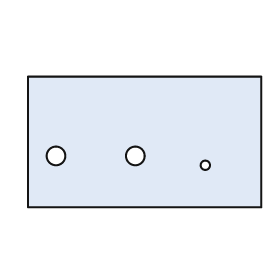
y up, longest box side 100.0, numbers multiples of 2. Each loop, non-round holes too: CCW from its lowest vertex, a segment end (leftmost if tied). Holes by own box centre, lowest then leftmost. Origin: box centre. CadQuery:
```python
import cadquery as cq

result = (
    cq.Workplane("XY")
    .moveTo(-50.0, -28.0)
    .lineTo(50.0, -28.0)
    .lineTo(50.0, 28.0)
    .lineTo(-50.0, 28.0)
    .close()
    .moveTo(26.0, -10.0)
    .circle(2.0)
    .moveTo(-38.0, -6.0)
    .circle(4.0)
    .moveTo(-4.0, -6.0)
    .circle(4.0)
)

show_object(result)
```